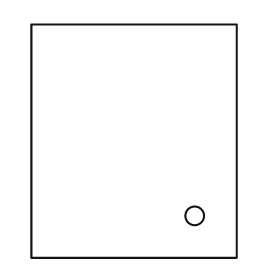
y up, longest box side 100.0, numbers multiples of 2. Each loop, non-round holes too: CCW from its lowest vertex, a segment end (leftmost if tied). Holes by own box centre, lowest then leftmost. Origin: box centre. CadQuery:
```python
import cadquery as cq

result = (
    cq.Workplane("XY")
    .moveTo(-44.0, -50.0)
    .lineTo(44.0, -50.0)
    .lineTo(44.0, 50.0)
    .lineTo(-44.0, 50.0)
    .close()
    .moveTo(26.0, -32.0)
    .circle(4.0)
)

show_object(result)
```